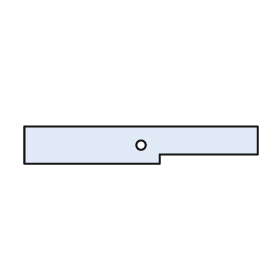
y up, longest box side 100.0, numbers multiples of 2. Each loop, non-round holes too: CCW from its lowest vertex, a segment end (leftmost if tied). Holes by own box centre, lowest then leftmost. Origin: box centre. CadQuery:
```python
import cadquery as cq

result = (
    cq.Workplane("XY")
    .moveTo(-50.0, -8.0)
    .lineTo(8.0, -8.0)
    .lineTo(8.0, -4.0)
    .lineTo(50.0, -4.0)
    .lineTo(50.0, 8.0)
    .lineTo(-50.0, 8.0)
    .close()
    .moveTo(0.0, 0.0)
    .circle(2.0)
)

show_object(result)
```